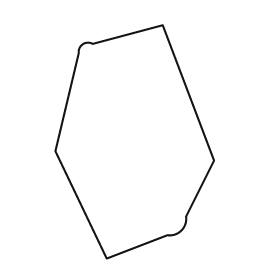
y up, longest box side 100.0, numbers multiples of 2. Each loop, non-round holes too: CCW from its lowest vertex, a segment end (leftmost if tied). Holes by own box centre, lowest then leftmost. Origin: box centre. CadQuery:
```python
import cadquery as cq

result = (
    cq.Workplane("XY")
    .moveTo(-12.0, -50.0)
    .lineTo(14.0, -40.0)
    .threePointArc((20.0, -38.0), (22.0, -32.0))
    .lineTo(34.0, -8.0)
    .lineTo(12.0, 50.0)
    .lineTo(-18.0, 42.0)
    .threePointArc((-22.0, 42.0), (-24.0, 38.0))
    .lineTo(-34.0, -4.0)
    .close()
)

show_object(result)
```